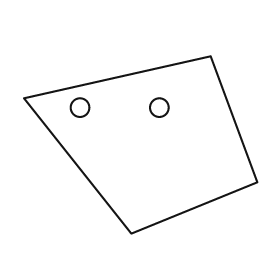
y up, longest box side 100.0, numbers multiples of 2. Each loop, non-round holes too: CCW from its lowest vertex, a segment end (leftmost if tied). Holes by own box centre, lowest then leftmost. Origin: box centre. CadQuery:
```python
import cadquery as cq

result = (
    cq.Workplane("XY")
    .moveTo(-4.0, -38.0)
    .lineTo(50.0, -16.0)
    .lineTo(30.0, 38.0)
    .lineTo(-50.0, 20.0)
    .close()
    .moveTo(-26.0, 16.0)
    .circle(4.0)
    .moveTo(8.0, 16.0)
    .circle(4.0)
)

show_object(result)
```